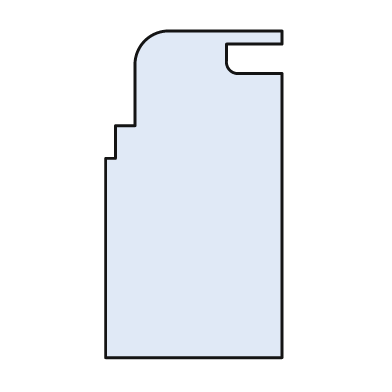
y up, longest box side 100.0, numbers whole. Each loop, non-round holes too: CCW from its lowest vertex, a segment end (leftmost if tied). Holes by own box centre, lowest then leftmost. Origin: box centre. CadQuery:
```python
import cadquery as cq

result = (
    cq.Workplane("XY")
    .moveTo(-27.0, -50.0)
    .lineTo(27.0, -50.0)
    .lineTo(27.0, 37.0)
    .lineTo(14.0, 37.0)
    .threePointArc((11.0, 38.0), (10.0, 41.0))
    .lineTo(10.0, 46.0)
    .lineTo(27.0, 46.0)
    .lineTo(27.0, 50.0)
    .lineTo(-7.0, 50.0)
    .threePointArc((-15.0, 47.0), (-18.0, 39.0))
    .lineTo(-18.0, 21.0)
    .lineTo(-24.0, 21.0)
    .lineTo(-24.0, 11.0)
    .lineTo(-27.0, 11.0)
    .close()
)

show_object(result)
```